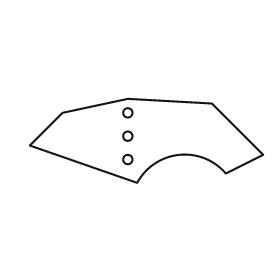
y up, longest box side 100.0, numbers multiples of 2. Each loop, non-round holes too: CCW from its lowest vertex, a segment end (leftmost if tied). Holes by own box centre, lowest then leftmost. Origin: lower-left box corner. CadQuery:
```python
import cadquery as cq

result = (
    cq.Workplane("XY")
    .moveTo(46.0, 0.0)
    .threePointArc((64.0, 12.0), (84.0, 4.0))
    .lineTo(100.0, 12.0)
    .lineTo(78.0, 34.0)
    .lineTo(42.0, 36.0)
    .lineTo(14.0, 30.0)
    .lineTo(0.0, 16.0)
    .close()
    .moveTo(42.0, 10.0)
    .circle(2.0)
    .moveTo(42.0, 20.0)
    .circle(2.0)
    .moveTo(42.0, 30.0)
    .circle(2.0)
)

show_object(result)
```